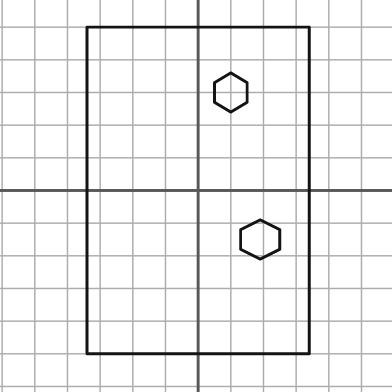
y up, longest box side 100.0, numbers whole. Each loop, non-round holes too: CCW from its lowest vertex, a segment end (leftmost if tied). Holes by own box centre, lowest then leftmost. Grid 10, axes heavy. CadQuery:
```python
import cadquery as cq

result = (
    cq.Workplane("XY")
    .moveTo(-34.0, -50.0)
    .lineTo(34.0, -50.0)
    .lineTo(34.0, 50.0)
    .lineTo(-34.0, 50.0)
    .close()
    .moveTo(19.0, -21.0)
    .lineTo(25.0, -18.0)
    .lineTo(25.0, -12.0)
    .lineTo(19.0, -9.0)
    .lineTo(13.0, -12.0)
    .lineTo(13.0, -18.0)
    .close()
    .moveTo(10.0, 24.0)
    .lineTo(15.0, 27.0)
    .lineTo(15.0, 33.0)
    .lineTo(10.0, 36.0)
    .lineTo(5.0, 33.0)
    .lineTo(5.0, 27.0)
    .close()
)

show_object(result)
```